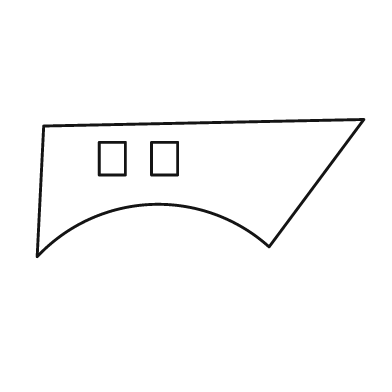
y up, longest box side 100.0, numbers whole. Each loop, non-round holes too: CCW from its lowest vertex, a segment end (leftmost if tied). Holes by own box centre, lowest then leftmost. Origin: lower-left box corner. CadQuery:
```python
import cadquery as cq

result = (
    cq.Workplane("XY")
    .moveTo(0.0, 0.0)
    .threePointArc((35.0, 16.0), (71.0, 3.0))
    .lineTo(100.0, 42.0)
    .lineTo(2.0, 40.0)
    .close()
    .moveTo(19.0, 25.0)
    .lineTo(27.0, 25.0)
    .lineTo(27.0, 35.0)
    .lineTo(19.0, 35.0)
    .close()
    .moveTo(35.0, 25.0)
    .lineTo(43.0, 25.0)
    .lineTo(43.0, 35.0)
    .lineTo(35.0, 35.0)
    .close()
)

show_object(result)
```